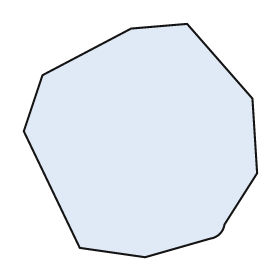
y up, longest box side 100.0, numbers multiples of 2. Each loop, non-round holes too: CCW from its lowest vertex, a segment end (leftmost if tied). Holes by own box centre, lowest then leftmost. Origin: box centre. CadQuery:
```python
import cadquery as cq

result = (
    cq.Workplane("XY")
    .moveTo(2.0, -50.0)
    .lineTo(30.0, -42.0)
    .threePointArc((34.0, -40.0), (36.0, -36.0))
    .lineTo(50.0, -14.0)
    .lineTo(48.0, 18.0)
    .lineTo(20.0, 50.0)
    .lineTo(-4.0, 48.0)
    .lineTo(-42.0, 28.0)
    .lineTo(-50.0, 4.0)
    .lineTo(-26.0, -46.0)
    .close()
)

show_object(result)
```